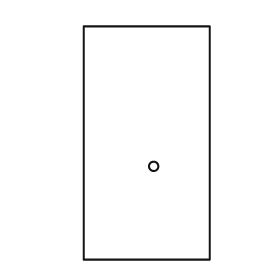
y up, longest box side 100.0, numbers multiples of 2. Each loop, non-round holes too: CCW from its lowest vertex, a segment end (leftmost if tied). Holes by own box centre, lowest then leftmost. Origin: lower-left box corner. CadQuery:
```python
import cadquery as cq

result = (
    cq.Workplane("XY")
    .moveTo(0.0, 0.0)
    .lineTo(54.0, 0.0)
    .lineTo(54.0, 100.0)
    .lineTo(0.0, 100.0)
    .close()
    .moveTo(30.0, 40.0)
    .circle(2.0)
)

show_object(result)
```